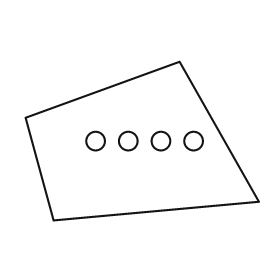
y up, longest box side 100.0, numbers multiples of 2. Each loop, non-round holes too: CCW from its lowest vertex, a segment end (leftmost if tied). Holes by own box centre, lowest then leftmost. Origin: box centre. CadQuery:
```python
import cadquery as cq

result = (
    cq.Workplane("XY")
    .moveTo(-38.0, -34.0)
    .lineTo(50.0, -26.0)
    .lineTo(16.0, 34.0)
    .lineTo(-50.0, 10.0)
    .close()
    .moveTo(-20.0, 0.0)
    .circle(4.0)
    .moveTo(-6.0, 0.0)
    .circle(4.0)
    .moveTo(8.0, 0.0)
    .circle(4.0)
    .moveTo(22.0, 0.0)
    .circle(4.0)
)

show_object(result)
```